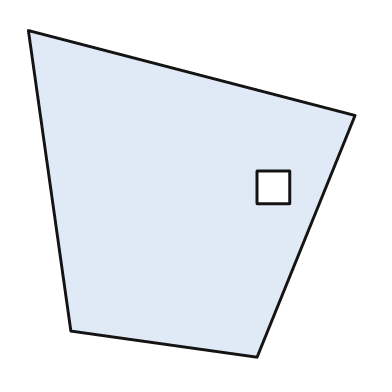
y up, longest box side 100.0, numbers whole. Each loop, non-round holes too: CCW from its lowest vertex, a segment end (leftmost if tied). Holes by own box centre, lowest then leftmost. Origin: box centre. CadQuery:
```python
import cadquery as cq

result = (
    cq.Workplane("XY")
    .moveTo(20.0, -50.0)
    .lineTo(50.0, 24.0)
    .lineTo(-50.0, 50.0)
    .lineTo(-37.0, -42.0)
    .close()
    .moveTo(20.0, -3.0)
    .lineTo(30.0, -3.0)
    .lineTo(30.0, 7.0)
    .lineTo(20.0, 7.0)
    .close()
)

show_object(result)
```